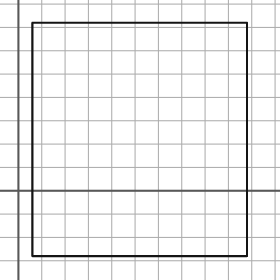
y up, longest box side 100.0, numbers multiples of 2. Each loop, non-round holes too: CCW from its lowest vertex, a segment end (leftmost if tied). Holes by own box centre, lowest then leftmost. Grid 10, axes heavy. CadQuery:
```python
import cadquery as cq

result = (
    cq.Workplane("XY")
    .moveTo(6.0, -28.0)
    .lineTo(98.0, -28.0)
    .lineTo(98.0, 72.0)
    .lineTo(6.0, 72.0)
    .close()
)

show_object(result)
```